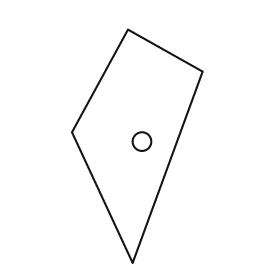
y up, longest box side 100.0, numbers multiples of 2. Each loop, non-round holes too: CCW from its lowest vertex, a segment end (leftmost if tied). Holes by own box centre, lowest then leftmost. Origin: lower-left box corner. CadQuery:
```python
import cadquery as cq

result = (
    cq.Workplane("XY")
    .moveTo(26.0, 0.0)
    .lineTo(56.0, 82.0)
    .lineTo(24.0, 100.0)
    .lineTo(0.0, 56.0)
    .close()
    .moveTo(30.0, 52.0)
    .circle(4.0)
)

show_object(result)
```